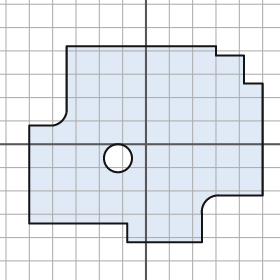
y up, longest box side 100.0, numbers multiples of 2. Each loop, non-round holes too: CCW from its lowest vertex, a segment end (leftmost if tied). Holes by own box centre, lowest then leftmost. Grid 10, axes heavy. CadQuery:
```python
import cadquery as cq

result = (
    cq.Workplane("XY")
    .moveTo(-8.0, -42.0)
    .lineTo(24.0, -42.0)
    .lineTo(24.0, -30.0)
    .threePointArc((26.0, -24.0), (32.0, -22.0))
    .lineTo(50.0, -22.0)
    .lineTo(50.0, 26.0)
    .lineTo(42.0, 26.0)
    .lineTo(42.0, 38.0)
    .lineTo(30.0, 38.0)
    .lineTo(30.0, 42.0)
    .lineTo(-34.0, 42.0)
    .lineTo(-34.0, 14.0)
    .threePointArc((-36.0, 10.0), (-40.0, 8.0))
    .lineTo(-50.0, 8.0)
    .lineTo(-50.0, -34.0)
    .lineTo(-8.0, -34.0)
    .close()
    .moveTo(-12.0, -6.0)
    .circle(6.0)
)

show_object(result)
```